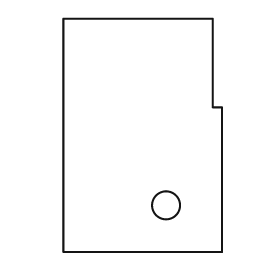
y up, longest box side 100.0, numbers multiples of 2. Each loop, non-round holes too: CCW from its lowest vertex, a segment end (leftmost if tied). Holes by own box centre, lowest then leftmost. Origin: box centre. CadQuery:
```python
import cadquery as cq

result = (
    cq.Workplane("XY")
    .moveTo(-34.0, -50.0)
    .lineTo(34.0, -50.0)
    .lineTo(34.0, 12.0)
    .lineTo(30.0, 12.0)
    .lineTo(30.0, 50.0)
    .lineTo(-34.0, 50.0)
    .close()
    .moveTo(10.0, -30.0)
    .circle(6.0)
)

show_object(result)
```